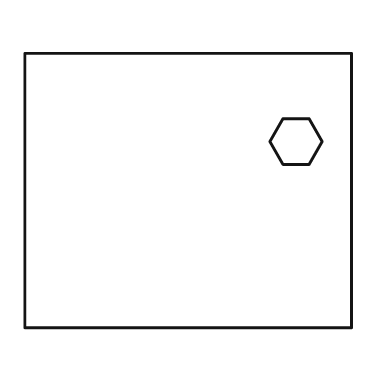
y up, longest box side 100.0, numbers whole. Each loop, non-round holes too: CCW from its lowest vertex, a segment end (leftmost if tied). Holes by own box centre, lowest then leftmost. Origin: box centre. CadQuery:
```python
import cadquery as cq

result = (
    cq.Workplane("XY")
    .moveTo(-50.0, -42.0)
    .lineTo(50.0, -42.0)
    .lineTo(50.0, 42.0)
    .lineTo(-50.0, 42.0)
    .close()
    .moveTo(29.0, 8.0)
    .lineTo(37.0, 8.0)
    .lineTo(41.0, 15.0)
    .lineTo(37.0, 22.0)
    .lineTo(29.0, 22.0)
    .lineTo(25.0, 15.0)
    .close()
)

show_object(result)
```